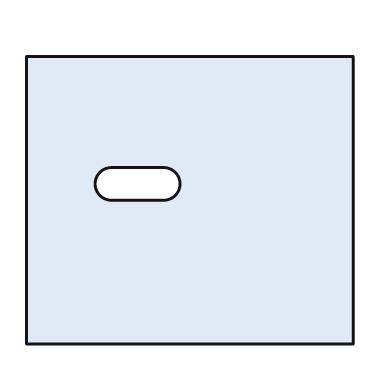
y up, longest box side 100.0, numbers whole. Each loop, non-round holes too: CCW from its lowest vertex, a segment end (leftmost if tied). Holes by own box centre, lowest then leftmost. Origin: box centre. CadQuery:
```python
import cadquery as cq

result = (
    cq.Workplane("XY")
    .moveTo(-50.0, -44.0)
    .lineTo(50.0, -44.0)
    .lineTo(50.0, 44.0)
    .lineTo(-50.0, 44.0)
    .close()
    .moveTo(-24.0, 0.0)
    .lineTo(-8.0, 0.0)
    .threePointArc((-3.0, 5.0), (-8.0, 10.0))
    .lineTo(-24.0, 10.0)
    .threePointArc((-29.0, 5.0), (-24.0, 0.0))
    .close()
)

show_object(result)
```